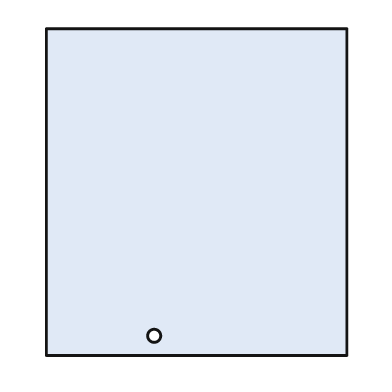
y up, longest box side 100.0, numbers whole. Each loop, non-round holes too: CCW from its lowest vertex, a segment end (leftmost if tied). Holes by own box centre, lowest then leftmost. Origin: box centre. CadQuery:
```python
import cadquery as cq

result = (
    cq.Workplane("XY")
    .moveTo(-46.0, -50.0)
    .lineTo(46.0, -50.0)
    .lineTo(46.0, 50.0)
    .lineTo(-46.0, 50.0)
    .close()
    .moveTo(-13.0, -44.0)
    .circle(2.0)
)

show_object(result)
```